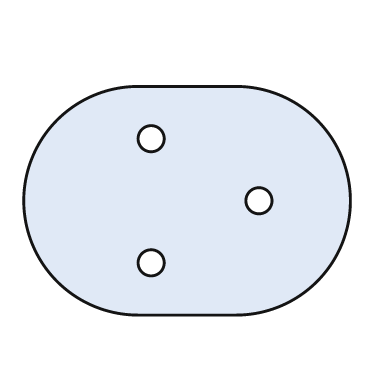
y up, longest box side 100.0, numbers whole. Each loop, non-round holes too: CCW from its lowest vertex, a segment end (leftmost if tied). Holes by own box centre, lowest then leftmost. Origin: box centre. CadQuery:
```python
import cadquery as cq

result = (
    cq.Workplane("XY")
    .moveTo(-15.0, -35.0)
    .lineTo(15.0, -35.0)
    .threePointArc((50.0, 0.0), (15.0, 35.0))
    .lineTo(-15.0, 35.0)
    .threePointArc((-50.0, 0.0), (-15.0, -35.0))
    .close()
    .moveTo(-11.0, -19.0)
    .circle(4.0)
    .moveTo(22.0, 0.0)
    .circle(4.0)
    .moveTo(-11.0, 19.0)
    .circle(4.0)
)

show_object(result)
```